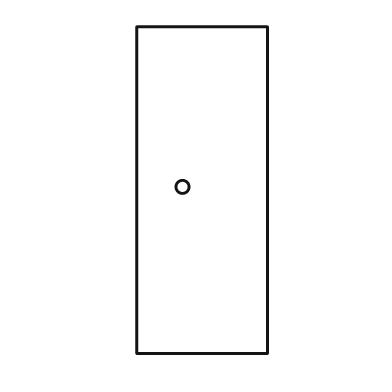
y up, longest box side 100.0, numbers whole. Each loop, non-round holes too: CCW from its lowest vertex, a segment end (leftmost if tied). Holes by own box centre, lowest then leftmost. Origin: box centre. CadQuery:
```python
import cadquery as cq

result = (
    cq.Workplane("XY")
    .moveTo(-20.0, -50.0)
    .lineTo(20.0, -50.0)
    .lineTo(20.0, 50.0)
    .lineTo(-20.0, 50.0)
    .close()
    .moveTo(-6.0, 1.0)
    .circle(2.0)
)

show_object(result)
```